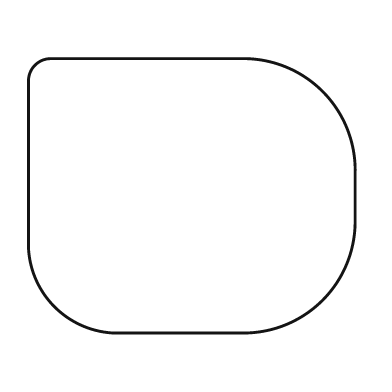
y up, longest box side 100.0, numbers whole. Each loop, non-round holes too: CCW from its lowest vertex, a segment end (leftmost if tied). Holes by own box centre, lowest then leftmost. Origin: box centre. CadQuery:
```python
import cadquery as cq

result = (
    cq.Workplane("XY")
    .moveTo(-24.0, -42.0)
    .lineTo(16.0, -42.0)
    .threePointArc((40.0, -32.0), (50.0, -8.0))
    .lineTo(50.0, 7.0)
    .threePointArc((40.0, 32.0), (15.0, 42.0))
    .lineTo(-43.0, 42.0)
    .threePointArc((-48.0, 40.0), (-50.0, 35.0))
    .lineTo(-50.0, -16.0)
    .threePointArc((-42.0, -34.0), (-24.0, -42.0))
    .close()
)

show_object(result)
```